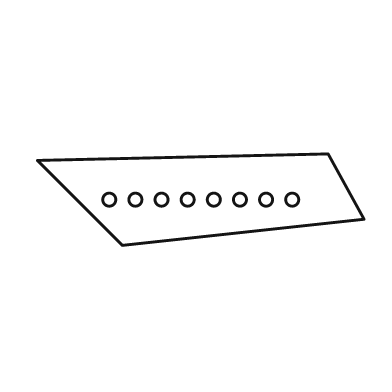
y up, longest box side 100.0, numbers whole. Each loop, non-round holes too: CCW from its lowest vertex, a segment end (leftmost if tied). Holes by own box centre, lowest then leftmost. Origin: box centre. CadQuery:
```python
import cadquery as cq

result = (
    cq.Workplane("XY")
    .moveTo(-24.0, -14.0)
    .lineTo(50.0, -6.0)
    .lineTo(39.0, 14.0)
    .lineTo(-50.0, 12.0)
    .close()
    .moveTo(-28.0, 0.0)
    .circle(2.0)
    .moveTo(-20.0, 0.0)
    .circle(2.0)
    .moveTo(-12.0, 0.0)
    .circle(2.0)
    .moveTo(-4.0, 0.0)
    .circle(2.0)
    .moveTo(4.0, 0.0)
    .circle(2.0)
    .moveTo(12.0, 0.0)
    .circle(2.0)
    .moveTo(20.0, 0.0)
    .circle(2.0)
    .moveTo(28.0, 0.0)
    .circle(2.0)
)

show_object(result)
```